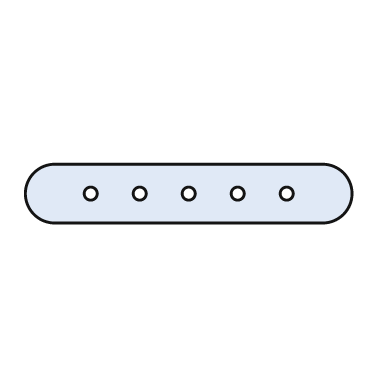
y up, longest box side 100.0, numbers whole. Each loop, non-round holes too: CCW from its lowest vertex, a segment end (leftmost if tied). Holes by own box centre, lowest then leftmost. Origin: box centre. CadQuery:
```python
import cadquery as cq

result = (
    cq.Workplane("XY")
    .moveTo(-41.0, -9.0)
    .lineTo(41.0, -9.0)
    .threePointArc((50.0, 0.0), (41.0, 9.0))
    .lineTo(-41.0, 9.0)
    .threePointArc((-50.0, 0.0), (-41.0, -9.0))
    .close()
    .moveTo(-30.0, 0.0)
    .circle(2.0)
    .moveTo(-15.0, 0.0)
    .circle(2.0)
    .moveTo(0.0, 0.0)
    .circle(2.0)
    .moveTo(15.0, 0.0)
    .circle(2.0)
    .moveTo(30.0, 0.0)
    .circle(2.0)
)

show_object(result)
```